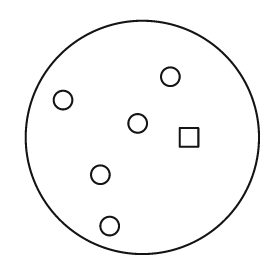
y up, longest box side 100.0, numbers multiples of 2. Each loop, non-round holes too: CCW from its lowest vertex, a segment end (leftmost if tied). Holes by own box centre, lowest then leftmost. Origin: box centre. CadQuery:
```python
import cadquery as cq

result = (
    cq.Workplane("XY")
    .moveTo(0.0, 0.0)
    .circle(50.0)
    .moveTo(-14.0, -38.0)
    .circle(4.0)
    .moveTo(-18.0, -16.0)
    .circle(4.0)
    .moveTo(16.0, -4.0)
    .lineTo(24.0, -4.0)
    .lineTo(24.0, 4.0)
    .lineTo(16.0, 4.0)
    .close()
    .moveTo(-2.0, 6.0)
    .circle(4.0)
    .moveTo(-34.0, 16.0)
    .circle(4.0)
    .moveTo(12.0, 26.0)
    .circle(4.0)
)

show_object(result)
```